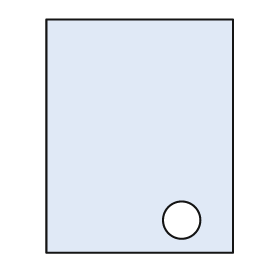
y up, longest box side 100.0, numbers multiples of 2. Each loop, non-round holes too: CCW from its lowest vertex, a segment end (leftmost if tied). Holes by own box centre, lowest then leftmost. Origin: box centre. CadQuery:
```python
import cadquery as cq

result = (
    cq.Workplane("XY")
    .moveTo(-40.0, -50.0)
    .lineTo(40.0, -50.0)
    .lineTo(40.0, 50.0)
    .lineTo(-40.0, 50.0)
    .close()
    .moveTo(18.0, -36.0)
    .circle(8.0)
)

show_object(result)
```